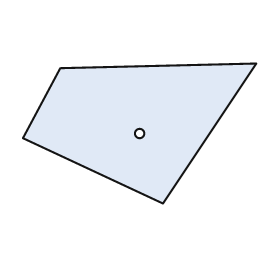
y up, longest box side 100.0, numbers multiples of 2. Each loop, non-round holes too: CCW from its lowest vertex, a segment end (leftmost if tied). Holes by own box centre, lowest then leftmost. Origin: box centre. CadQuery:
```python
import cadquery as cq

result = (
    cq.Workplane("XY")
    .moveTo(10.0, -30.0)
    .lineTo(50.0, 30.0)
    .lineTo(-34.0, 28.0)
    .lineTo(-50.0, -2.0)
    .close()
    .moveTo(0.0, 0.0)
    .circle(2.0)
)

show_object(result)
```